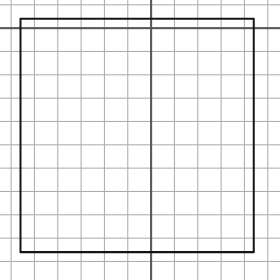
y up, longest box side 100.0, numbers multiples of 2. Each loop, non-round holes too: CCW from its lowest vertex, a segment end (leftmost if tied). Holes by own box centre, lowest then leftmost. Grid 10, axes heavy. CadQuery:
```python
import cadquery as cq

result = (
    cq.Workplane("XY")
    .moveTo(-56.0, -96.0)
    .lineTo(44.0, -96.0)
    .lineTo(44.0, 4.0)
    .lineTo(-56.0, 4.0)
    .close()
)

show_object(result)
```